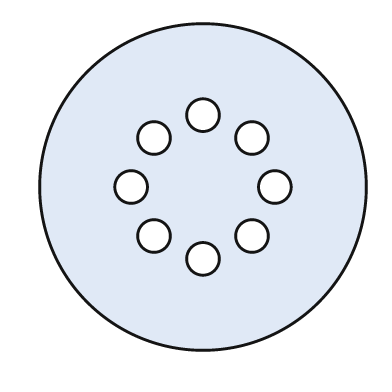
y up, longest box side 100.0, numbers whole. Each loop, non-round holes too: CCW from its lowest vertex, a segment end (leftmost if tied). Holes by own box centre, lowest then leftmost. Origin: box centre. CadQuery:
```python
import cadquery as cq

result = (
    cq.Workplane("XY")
    .moveTo(0.0, 0.0)
    .circle(50.0)
    .moveTo(0.0, -22.0)
    .circle(5.0)
    .moveTo(-15.0, -15.0)
    .circle(5.0)
    .moveTo(15.0, -15.0)
    .circle(5.0)
    .moveTo(-22.0, 0.0)
    .circle(5.0)
    .moveTo(22.0, 0.0)
    .circle(5.0)
    .moveTo(-15.0, 15.0)
    .circle(5.0)
    .moveTo(15.0, 15.0)
    .circle(5.0)
    .moveTo(0.0, 22.0)
    .circle(5.0)
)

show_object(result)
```